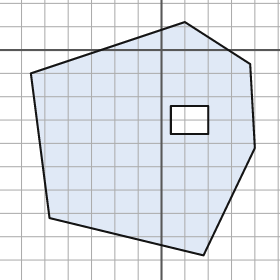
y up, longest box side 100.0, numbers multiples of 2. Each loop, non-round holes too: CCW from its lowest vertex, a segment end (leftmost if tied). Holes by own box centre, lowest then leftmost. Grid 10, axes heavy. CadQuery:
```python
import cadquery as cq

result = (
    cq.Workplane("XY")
    .moveTo(18.0, -88.0)
    .lineTo(40.0, -42.0)
    .lineTo(38.0, -6.0)
    .lineTo(10.0, 12.0)
    .lineTo(-56.0, -10.0)
    .lineTo(-48.0, -72.0)
    .close()
    .moveTo(4.0, -36.0)
    .lineTo(20.0, -36.0)
    .lineTo(20.0, -24.0)
    .lineTo(4.0, -24.0)
    .close()
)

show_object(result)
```